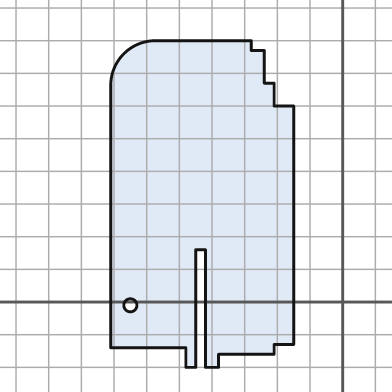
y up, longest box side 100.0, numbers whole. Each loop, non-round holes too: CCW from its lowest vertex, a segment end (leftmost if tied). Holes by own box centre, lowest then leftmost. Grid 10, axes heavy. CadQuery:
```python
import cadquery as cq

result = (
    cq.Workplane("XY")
    .moveTo(-48.0, -20.0)
    .lineTo(-45.0, -20.0)
    .lineTo(-45.0, 16.0)
    .lineTo(-42.0, 16.0)
    .lineTo(-42.0, -20.0)
    .lineTo(-38.0, -20.0)
    .lineTo(-38.0, -16.0)
    .lineTo(-21.0, -16.0)
    .lineTo(-21.0, -13.0)
    .lineTo(-15.0, -13.0)
    .lineTo(-15.0, 60.0)
    .lineTo(-21.0, 60.0)
    .lineTo(-21.0, 67.0)
    .lineTo(-24.0, 67.0)
    .lineTo(-24.0, 77.0)
    .lineTo(-28.0, 77.0)
    .lineTo(-28.0, 80.0)
    .lineTo(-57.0, 80.0)
    .threePointArc((-67.0, 76.0), (-71.0, 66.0))
    .lineTo(-71.0, -14.0)
    .lineTo(-48.0, -14.0)
    .close()
    .moveTo(-65.0, -1.0)
    .circle(2.0)
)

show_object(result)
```